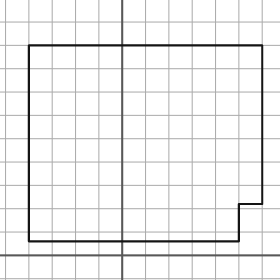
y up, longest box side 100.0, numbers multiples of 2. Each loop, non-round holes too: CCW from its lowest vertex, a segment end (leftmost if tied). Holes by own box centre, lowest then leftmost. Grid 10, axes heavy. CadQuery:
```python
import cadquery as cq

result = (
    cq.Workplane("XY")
    .moveTo(-40.0, 6.0)
    .lineTo(50.0, 6.0)
    .lineTo(50.0, 22.0)
    .lineTo(60.0, 22.0)
    .lineTo(60.0, 90.0)
    .lineTo(-40.0, 90.0)
    .close()
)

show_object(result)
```